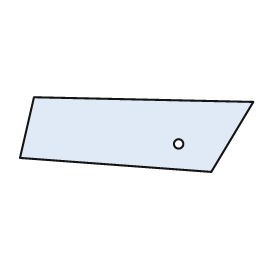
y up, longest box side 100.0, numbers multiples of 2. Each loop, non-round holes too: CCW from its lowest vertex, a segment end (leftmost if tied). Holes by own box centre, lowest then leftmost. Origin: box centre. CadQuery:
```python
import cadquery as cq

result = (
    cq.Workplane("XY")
    .moveTo(32.0, -16.0)
    .lineTo(50.0, 14.0)
    .lineTo(-44.0, 16.0)
    .lineTo(-50.0, -10.0)
    .close()
    .moveTo(18.0, -4.0)
    .circle(2.0)
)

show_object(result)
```